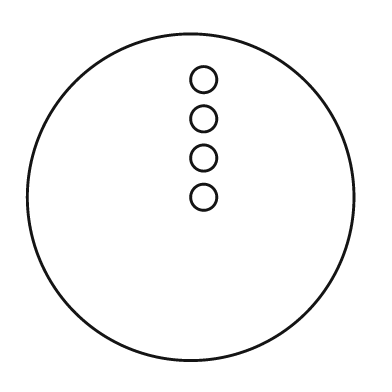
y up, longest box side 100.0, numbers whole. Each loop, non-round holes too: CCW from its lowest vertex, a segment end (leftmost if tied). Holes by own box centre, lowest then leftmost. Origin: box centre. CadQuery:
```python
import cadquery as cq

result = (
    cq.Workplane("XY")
    .moveTo(0.0, 0.0)
    .circle(50.0)
    .moveTo(4.0, 0.0)
    .circle(4.0)
    .moveTo(4.0, 12.0)
    .circle(4.0)
    .moveTo(4.0, 24.0)
    .circle(4.0)
    .moveTo(4.0, 36.0)
    .circle(4.0)
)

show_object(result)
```